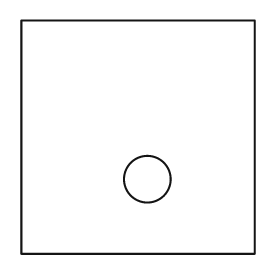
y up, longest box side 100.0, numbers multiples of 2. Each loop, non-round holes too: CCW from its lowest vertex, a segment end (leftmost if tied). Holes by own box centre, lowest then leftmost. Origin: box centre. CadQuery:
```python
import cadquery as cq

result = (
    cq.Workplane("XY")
    .moveTo(-50.0, -50.0)
    .lineTo(50.0, -50.0)
    .lineTo(50.0, 50.0)
    .lineTo(-50.0, 50.0)
    .close()
    .moveTo(4.0, -18.0)
    .circle(10.0)
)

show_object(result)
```